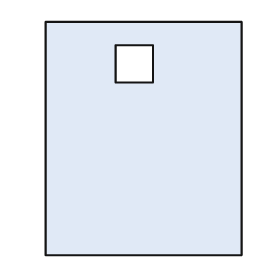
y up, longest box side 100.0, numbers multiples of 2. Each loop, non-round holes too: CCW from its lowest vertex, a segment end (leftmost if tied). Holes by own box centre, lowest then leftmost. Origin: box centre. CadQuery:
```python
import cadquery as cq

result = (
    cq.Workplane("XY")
    .moveTo(-42.0, -50.0)
    .lineTo(42.0, -50.0)
    .lineTo(42.0, 50.0)
    .lineTo(-42.0, 50.0)
    .close()
    .moveTo(-12.0, 24.0)
    .lineTo(4.0, 24.0)
    .lineTo(4.0, 40.0)
    .lineTo(-12.0, 40.0)
    .close()
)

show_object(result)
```